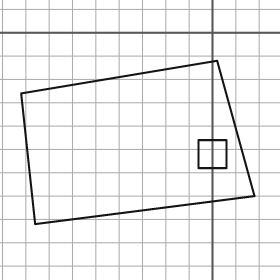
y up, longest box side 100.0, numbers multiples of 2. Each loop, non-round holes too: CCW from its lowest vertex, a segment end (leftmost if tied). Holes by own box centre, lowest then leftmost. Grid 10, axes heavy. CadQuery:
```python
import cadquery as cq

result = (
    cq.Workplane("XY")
    .moveTo(-76.0, -82.0)
    .lineTo(18.0, -70.0)
    .lineTo(2.0, -12.0)
    .lineTo(-82.0, -26.0)
    .close()
    .moveTo(-6.0, -58.0)
    .lineTo(6.0, -58.0)
    .lineTo(6.0, -46.0)
    .lineTo(-6.0, -46.0)
    .close()
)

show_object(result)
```